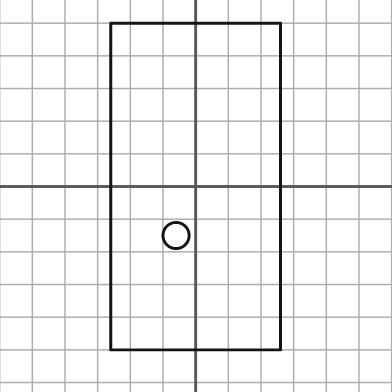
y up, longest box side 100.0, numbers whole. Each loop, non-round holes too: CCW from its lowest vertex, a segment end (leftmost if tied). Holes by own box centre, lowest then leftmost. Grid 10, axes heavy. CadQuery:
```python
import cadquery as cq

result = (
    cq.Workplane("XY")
    .moveTo(-26.0, -50.0)
    .lineTo(26.0, -50.0)
    .lineTo(26.0, 50.0)
    .lineTo(-26.0, 50.0)
    .close()
    .moveTo(-6.0, -15.0)
    .circle(4.0)
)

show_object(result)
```